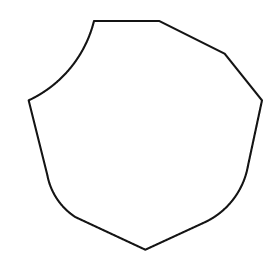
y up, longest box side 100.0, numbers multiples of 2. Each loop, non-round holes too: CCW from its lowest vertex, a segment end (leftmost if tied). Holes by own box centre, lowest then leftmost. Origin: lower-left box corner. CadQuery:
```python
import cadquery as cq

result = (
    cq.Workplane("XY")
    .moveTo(50.0, 0.0)
    .lineTo(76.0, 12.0)
    .threePointArc((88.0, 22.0), (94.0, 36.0))
    .lineTo(100.0, 64.0)
    .lineTo(84.0, 84.0)
    .lineTo(56.0, 98.0)
    .lineTo(28.0, 98.0)
    .threePointArc((18.0, 78.0), (0.0, 64.0))
    .lineTo(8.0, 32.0)
    .threePointArc((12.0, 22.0), (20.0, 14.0))
    .close()
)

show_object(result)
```